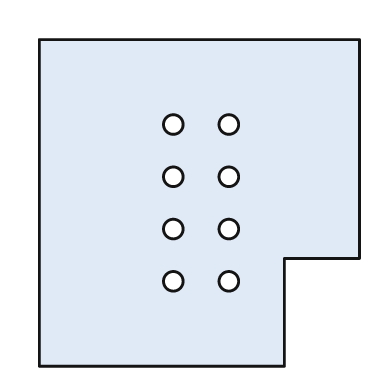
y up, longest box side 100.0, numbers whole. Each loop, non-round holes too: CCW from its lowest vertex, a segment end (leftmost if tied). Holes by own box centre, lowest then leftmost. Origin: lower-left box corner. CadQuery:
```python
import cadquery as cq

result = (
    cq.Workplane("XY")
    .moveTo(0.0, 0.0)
    .lineTo(75.0, 0.0)
    .lineTo(75.0, 33.0)
    .lineTo(98.0, 33.0)
    .lineTo(98.0, 100.0)
    .lineTo(0.0, 100.0)
    .close()
    .moveTo(41.0, 26.0)
    .circle(3.0)
    .moveTo(58.0, 26.0)
    .circle(3.0)
    .moveTo(41.0, 42.0)
    .circle(3.0)
    .moveTo(58.0, 42.0)
    .circle(3.0)
    .moveTo(41.0, 58.0)
    .circle(3.0)
    .moveTo(58.0, 58.0)
    .circle(3.0)
    .moveTo(41.0, 74.0)
    .circle(3.0)
    .moveTo(58.0, 74.0)
    .circle(3.0)
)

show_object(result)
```